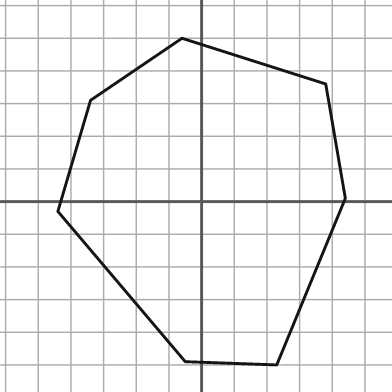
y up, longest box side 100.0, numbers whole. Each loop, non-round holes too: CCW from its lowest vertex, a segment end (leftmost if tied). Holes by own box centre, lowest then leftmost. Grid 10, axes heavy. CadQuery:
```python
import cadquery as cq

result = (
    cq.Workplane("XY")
    .moveTo(23.0, -50.0)
    .lineTo(44.0, 1.0)
    .lineTo(38.0, 36.0)
    .lineTo(-6.0, 50.0)
    .lineTo(-34.0, 31.0)
    .lineTo(-44.0, -3.0)
    .lineTo(-5.0, -49.0)
    .close()
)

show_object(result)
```